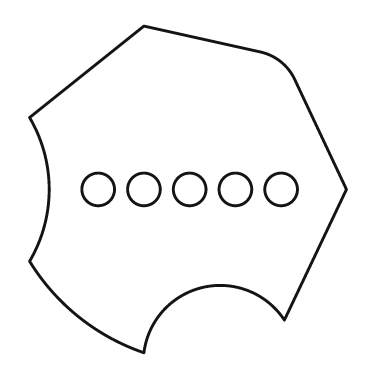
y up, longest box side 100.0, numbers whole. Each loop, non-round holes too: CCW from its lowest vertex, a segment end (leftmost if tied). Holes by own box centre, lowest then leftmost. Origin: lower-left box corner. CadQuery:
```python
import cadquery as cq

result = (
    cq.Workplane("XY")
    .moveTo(35.0, 0.0)
    .threePointArc((53.0, 20.0), (78.0, 10.0))
    .lineTo(97.0, 50.0)
    .lineTo(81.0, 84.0)
    .threePointArc((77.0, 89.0), (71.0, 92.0))
    .lineTo(35.0, 100.0)
    .lineTo(0.0, 72.0)
    .threePointArc((6.0, 50.0), (0.0, 28.0))
    .threePointArc((15.0, 11.0), (35.0, 0.0))
    .close()
    .moveTo(21.0, 50.0)
    .circle(5.0)
    .moveTo(35.0, 50.0)
    .circle(5.0)
    .moveTo(49.0, 50.0)
    .circle(5.0)
    .moveTo(63.0, 50.0)
    .circle(5.0)
    .moveTo(77.0, 50.0)
    .circle(5.0)
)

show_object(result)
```